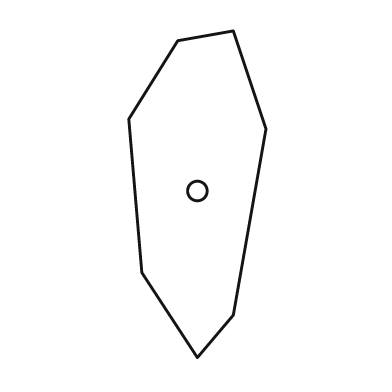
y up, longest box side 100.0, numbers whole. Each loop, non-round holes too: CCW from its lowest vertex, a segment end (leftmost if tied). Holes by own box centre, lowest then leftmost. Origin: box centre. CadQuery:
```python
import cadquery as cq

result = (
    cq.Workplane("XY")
    .moveTo(0.0, -50.0)
    .lineTo(11.0, -37.0)
    .lineTo(21.0, 20.0)
    .lineTo(11.0, 50.0)
    .lineTo(-6.0, 47.0)
    .lineTo(-21.0, 23.0)
    .lineTo(-17.0, -24.0)
    .close()
    .moveTo(0.0, 1.0)
    .circle(3.0)
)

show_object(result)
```